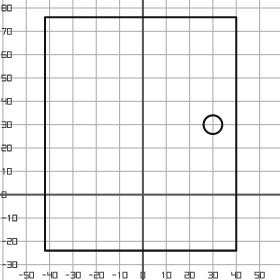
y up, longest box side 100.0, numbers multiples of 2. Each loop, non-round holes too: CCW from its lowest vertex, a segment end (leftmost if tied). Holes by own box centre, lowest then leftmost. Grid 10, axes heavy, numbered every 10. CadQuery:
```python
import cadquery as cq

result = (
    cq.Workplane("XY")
    .moveTo(-42.0, -24.0)
    .lineTo(40.0, -24.0)
    .lineTo(40.0, 76.0)
    .lineTo(-42.0, 76.0)
    .close()
    .moveTo(30.0, 30.0)
    .circle(4.0)
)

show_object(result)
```